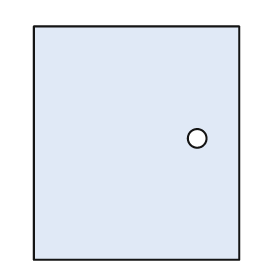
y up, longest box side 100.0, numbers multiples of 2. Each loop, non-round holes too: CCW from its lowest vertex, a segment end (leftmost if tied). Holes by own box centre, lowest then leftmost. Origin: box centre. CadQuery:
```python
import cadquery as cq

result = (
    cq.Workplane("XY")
    .moveTo(-44.0, -50.0)
    .lineTo(44.0, -50.0)
    .lineTo(44.0, 50.0)
    .lineTo(-44.0, 50.0)
    .close()
    .moveTo(26.0, 2.0)
    .circle(4.0)
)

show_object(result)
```